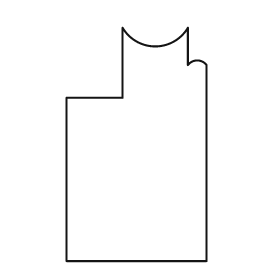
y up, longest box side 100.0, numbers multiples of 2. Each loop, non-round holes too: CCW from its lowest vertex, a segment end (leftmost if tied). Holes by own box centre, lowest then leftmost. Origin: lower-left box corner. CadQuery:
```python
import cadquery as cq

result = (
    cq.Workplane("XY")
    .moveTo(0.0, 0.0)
    .lineTo(60.0, 0.0)
    .lineTo(60.0, 84.0)
    .threePointArc((56.0, 86.0), (52.0, 84.0))
    .lineTo(52.0, 100.0)
    .threePointArc((38.0, 92.0), (24.0, 100.0))
    .lineTo(24.0, 70.0)
    .lineTo(0.0, 70.0)
    .close()
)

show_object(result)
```